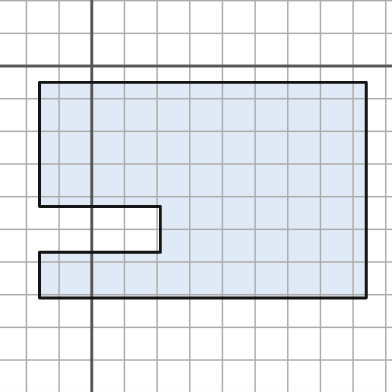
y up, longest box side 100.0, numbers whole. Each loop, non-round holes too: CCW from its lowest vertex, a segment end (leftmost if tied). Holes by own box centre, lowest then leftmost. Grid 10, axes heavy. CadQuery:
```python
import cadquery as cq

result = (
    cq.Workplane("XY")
    .moveTo(-16.0, -71.0)
    .lineTo(84.0, -71.0)
    .lineTo(84.0, -5.0)
    .lineTo(-16.0, -5.0)
    .lineTo(-16.0, -43.0)
    .lineTo(21.0, -43.0)
    .lineTo(21.0, -57.0)
    .lineTo(-16.0, -57.0)
    .close()
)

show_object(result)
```